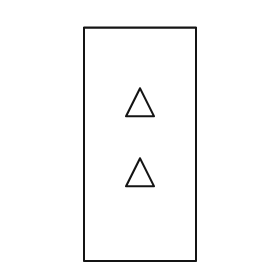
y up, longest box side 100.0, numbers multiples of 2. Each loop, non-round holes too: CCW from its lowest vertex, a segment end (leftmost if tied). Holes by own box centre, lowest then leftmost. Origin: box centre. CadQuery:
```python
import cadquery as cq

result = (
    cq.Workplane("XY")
    .moveTo(-24.0, -50.0)
    .lineTo(24.0, -50.0)
    .lineTo(24.0, 50.0)
    .lineTo(-24.0, 50.0)
    .close()
    .moveTo(-6.0, -18.0)
    .lineTo(6.0, -18.0)
    .lineTo(0.0, -6.0)
    .close()
    .moveTo(-6.0, 12.0)
    .lineTo(6.0, 12.0)
    .lineTo(0.0, 24.0)
    .close()
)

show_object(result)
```